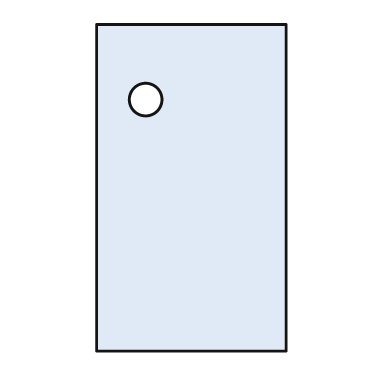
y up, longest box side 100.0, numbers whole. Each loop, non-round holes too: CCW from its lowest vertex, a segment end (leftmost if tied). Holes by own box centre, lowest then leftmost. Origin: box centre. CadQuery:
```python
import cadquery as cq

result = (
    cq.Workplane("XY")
    .moveTo(-29.0, -50.0)
    .lineTo(29.0, -50.0)
    .lineTo(29.0, 50.0)
    .lineTo(-29.0, 50.0)
    .close()
    .moveTo(-14.0, 27.0)
    .circle(5.0)
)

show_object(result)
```